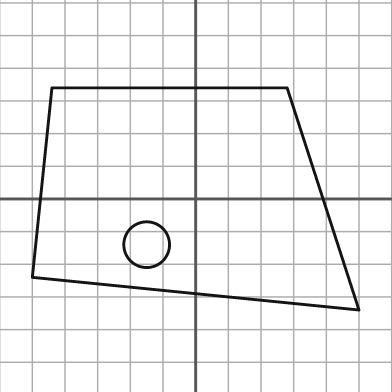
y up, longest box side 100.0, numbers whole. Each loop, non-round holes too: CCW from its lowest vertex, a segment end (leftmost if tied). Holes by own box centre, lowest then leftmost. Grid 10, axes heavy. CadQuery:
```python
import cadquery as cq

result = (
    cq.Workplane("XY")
    .moveTo(50.0, -34.0)
    .lineTo(28.0, 34.0)
    .lineTo(-44.0, 34.0)
    .lineTo(-50.0, -24.0)
    .close()
    .moveTo(-15.0, -14.0)
    .circle(7.0)
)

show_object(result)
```